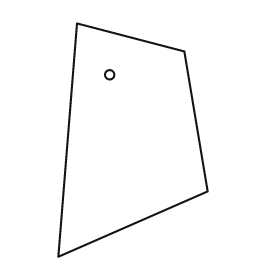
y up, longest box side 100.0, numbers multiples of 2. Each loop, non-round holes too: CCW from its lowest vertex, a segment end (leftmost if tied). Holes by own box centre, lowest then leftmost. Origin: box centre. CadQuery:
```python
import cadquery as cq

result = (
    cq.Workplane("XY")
    .moveTo(-32.0, -50.0)
    .lineTo(32.0, -22.0)
    .lineTo(22.0, 38.0)
    .lineTo(-24.0, 50.0)
    .close()
    .moveTo(-10.0, 28.0)
    .circle(2.0)
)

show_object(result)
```